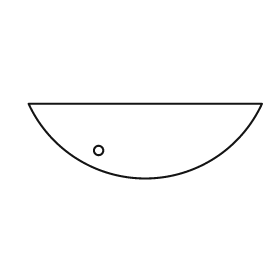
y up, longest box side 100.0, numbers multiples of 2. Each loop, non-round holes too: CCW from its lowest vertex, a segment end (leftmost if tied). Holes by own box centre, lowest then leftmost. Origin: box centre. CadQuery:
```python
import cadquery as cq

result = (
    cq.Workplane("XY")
    .moveTo(-50.0, 16.0)
    .threePointArc((0.0, -16.0), (50.0, 16.0))
    .close()
    .moveTo(-20.0, -4.0)
    .circle(2.0)
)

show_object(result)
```